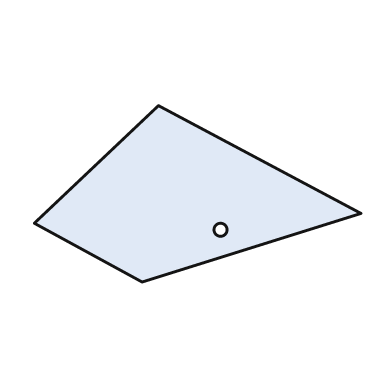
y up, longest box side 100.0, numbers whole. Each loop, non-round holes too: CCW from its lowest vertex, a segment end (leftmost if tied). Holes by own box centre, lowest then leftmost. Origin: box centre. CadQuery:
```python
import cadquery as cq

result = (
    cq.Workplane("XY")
    .moveTo(-17.0, -27.0)
    .lineTo(50.0, -6.0)
    .lineTo(-12.0, 27.0)
    .lineTo(-50.0, -9.0)
    .close()
    .moveTo(7.0, -11.0)
    .circle(2.0)
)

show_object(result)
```